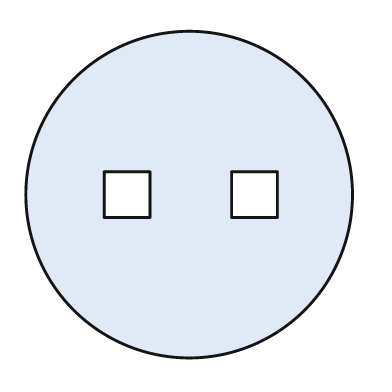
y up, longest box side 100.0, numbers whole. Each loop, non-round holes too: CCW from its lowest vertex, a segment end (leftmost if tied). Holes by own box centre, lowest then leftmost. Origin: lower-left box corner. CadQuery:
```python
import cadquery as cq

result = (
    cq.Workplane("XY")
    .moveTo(50.0, 50.0)
    .circle(50.0)
    .moveTo(24.0, 43.0)
    .lineTo(38.0, 43.0)
    .lineTo(38.0, 57.0)
    .lineTo(24.0, 57.0)
    .close()
    .moveTo(63.0, 43.0)
    .lineTo(77.0, 43.0)
    .lineTo(77.0, 57.0)
    .lineTo(63.0, 57.0)
    .close()
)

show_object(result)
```